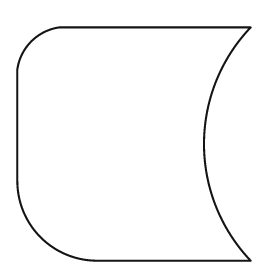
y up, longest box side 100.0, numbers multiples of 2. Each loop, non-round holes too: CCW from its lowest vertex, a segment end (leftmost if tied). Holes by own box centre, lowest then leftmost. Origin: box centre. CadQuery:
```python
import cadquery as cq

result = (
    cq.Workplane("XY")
    .moveTo(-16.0, -50.0)
    .lineTo(50.0, -50.0)
    .threePointArc((30.0, 0.0), (50.0, 50.0))
    .lineTo(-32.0, 50.0)
    .threePointArc((-44.0, 44.0), (-50.0, 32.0))
    .lineTo(-50.0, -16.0)
    .threePointArc((-40.0, -40.0), (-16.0, -50.0))
    .close()
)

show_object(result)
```